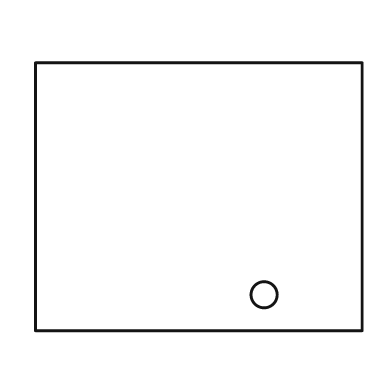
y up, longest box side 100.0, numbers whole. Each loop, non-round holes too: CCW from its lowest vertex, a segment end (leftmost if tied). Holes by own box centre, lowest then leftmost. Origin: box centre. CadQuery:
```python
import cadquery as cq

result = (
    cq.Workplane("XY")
    .moveTo(-50.0, -41.0)
    .lineTo(50.0, -41.0)
    .lineTo(50.0, 41.0)
    .lineTo(-50.0, 41.0)
    .close()
    .moveTo(20.0, -30.0)
    .circle(4.0)
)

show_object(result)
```